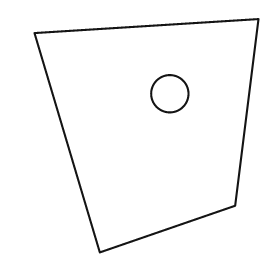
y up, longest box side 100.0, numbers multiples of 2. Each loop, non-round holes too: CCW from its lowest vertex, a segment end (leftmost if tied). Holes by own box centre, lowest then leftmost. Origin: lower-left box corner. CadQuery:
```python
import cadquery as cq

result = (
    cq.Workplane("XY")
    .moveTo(28.0, 0.0)
    .lineTo(86.0, 20.0)
    .lineTo(96.0, 100.0)
    .lineTo(0.0, 94.0)
    .close()
    .moveTo(58.0, 68.0)
    .circle(8.0)
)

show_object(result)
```